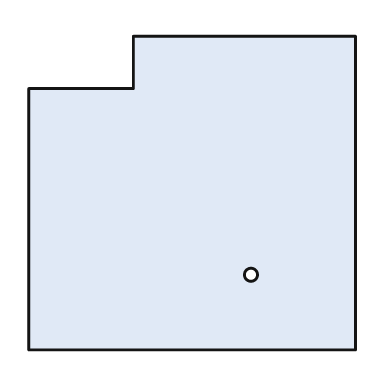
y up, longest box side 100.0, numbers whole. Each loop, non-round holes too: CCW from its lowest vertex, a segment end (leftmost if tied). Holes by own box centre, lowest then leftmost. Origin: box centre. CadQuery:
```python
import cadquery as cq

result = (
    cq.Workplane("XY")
    .moveTo(-50.0, -48.0)
    .lineTo(50.0, -48.0)
    .lineTo(50.0, 48.0)
    .lineTo(-18.0, 48.0)
    .lineTo(-18.0, 32.0)
    .lineTo(-50.0, 32.0)
    .close()
    .moveTo(18.0, -25.0)
    .circle(2.0)
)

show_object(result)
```